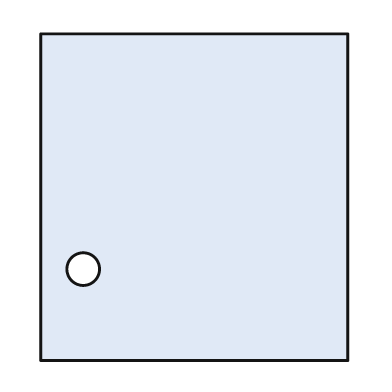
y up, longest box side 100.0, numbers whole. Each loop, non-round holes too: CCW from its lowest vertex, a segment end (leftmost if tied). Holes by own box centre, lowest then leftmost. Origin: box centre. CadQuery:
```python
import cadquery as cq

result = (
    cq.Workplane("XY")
    .moveTo(-47.0, -50.0)
    .lineTo(47.0, -50.0)
    .lineTo(47.0, 50.0)
    .lineTo(-47.0, 50.0)
    .close()
    .moveTo(-34.0, -22.0)
    .circle(5.0)
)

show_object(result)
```